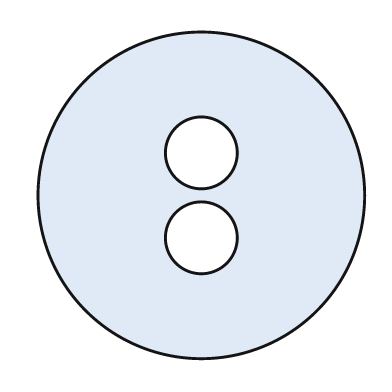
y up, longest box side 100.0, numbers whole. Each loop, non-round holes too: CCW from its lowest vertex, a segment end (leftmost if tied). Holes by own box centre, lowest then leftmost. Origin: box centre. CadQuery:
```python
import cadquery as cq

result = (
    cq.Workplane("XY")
    .moveTo(0.0, 0.0)
    .circle(50.0)
    .moveTo(0.0, -13.0)
    .circle(11.0)
    .moveTo(0.0, 13.0)
    .circle(11.0)
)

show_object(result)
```